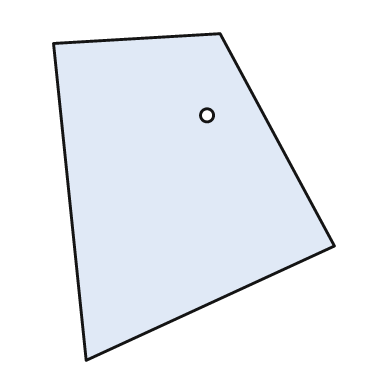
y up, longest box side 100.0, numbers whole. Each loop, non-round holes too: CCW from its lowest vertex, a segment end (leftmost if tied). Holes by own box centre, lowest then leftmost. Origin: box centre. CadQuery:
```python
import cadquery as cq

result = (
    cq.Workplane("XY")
    .moveTo(-33.0, -50.0)
    .lineTo(43.0, -15.0)
    .lineTo(8.0, 50.0)
    .lineTo(-43.0, 47.0)
    .close()
    .moveTo(4.0, 25.0)
    .circle(2.0)
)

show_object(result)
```